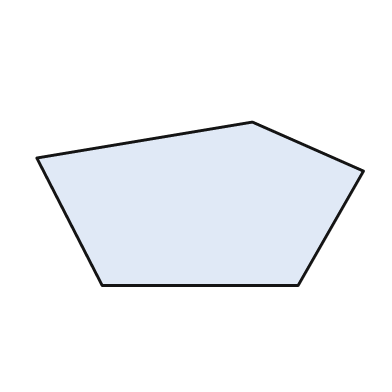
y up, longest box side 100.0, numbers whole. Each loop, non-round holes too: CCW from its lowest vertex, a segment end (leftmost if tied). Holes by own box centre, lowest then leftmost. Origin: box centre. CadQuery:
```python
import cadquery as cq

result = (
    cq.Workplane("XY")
    .moveTo(-30.0, -25.0)
    .lineTo(30.0, -25.0)
    .lineTo(50.0, 10.0)
    .lineTo(16.0, 25.0)
    .lineTo(-50.0, 14.0)
    .close()
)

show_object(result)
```